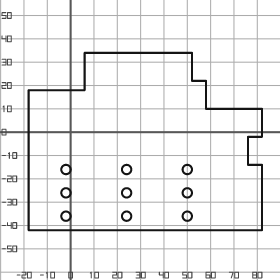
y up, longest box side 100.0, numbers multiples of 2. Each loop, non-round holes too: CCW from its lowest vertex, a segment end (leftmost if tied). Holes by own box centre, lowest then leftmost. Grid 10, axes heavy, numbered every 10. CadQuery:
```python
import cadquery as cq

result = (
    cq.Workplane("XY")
    .moveTo(-18.0, -42.0)
    .lineTo(82.0, -42.0)
    .lineTo(82.0, -14.0)
    .lineTo(76.0, -14.0)
    .lineTo(76.0, -2.0)
    .lineTo(82.0, -2.0)
    .lineTo(82.0, 10.0)
    .lineTo(58.0, 10.0)
    .lineTo(58.0, 22.0)
    .lineTo(52.0, 22.0)
    .lineTo(52.0, 34.0)
    .lineTo(6.0, 34.0)
    .lineTo(6.0, 18.0)
    .lineTo(-18.0, 18.0)
    .close()
    .moveTo(-2.0, -36.0)
    .circle(2.0)
    .moveTo(24.0, -36.0)
    .circle(2.0)
    .moveTo(50.0, -36.0)
    .circle(2.0)
    .moveTo(-2.0, -26.0)
    .circle(2.0)
    .moveTo(24.0, -26.0)
    .circle(2.0)
    .moveTo(50.0, -26.0)
    .circle(2.0)
    .moveTo(-2.0, -16.0)
    .circle(2.0)
    .moveTo(24.0, -16.0)
    .circle(2.0)
    .moveTo(50.0, -16.0)
    .circle(2.0)
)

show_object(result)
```